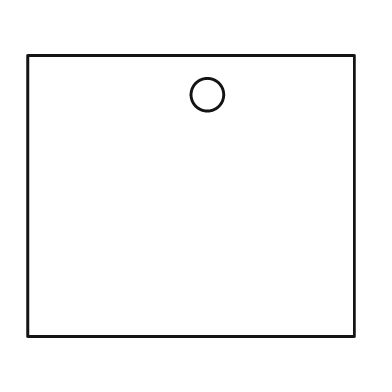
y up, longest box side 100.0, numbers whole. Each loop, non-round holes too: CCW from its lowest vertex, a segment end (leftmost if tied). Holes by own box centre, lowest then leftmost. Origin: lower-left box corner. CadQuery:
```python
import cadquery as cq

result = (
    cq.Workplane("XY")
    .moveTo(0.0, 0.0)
    .lineTo(100.0, 0.0)
    .lineTo(100.0, 86.0)
    .lineTo(0.0, 86.0)
    .close()
    .moveTo(55.0, 74.0)
    .circle(5.0)
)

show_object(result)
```